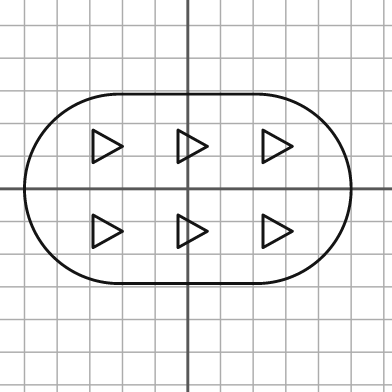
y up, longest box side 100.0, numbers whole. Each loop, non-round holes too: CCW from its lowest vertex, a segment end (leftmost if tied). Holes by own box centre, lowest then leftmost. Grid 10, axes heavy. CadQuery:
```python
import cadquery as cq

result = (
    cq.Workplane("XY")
    .moveTo(-21.0, -29.0)
    .lineTo(21.0, -29.0)
    .threePointArc((50.0, 0.0), (21.0, 29.0))
    .lineTo(-21.0, 29.0)
    .threePointArc((-50.0, 0.0), (-21.0, -29.0))
    .close()
    .moveTo(-29.0, -18.0)
    .lineTo(-20.0, -13.0)
    .lineTo(-29.0, -8.0)
    .close()
    .moveTo(-3.0, -18.0)
    .lineTo(6.0, -13.0)
    .lineTo(-3.0, -8.0)
    .close()
    .moveTo(23.0, -18.0)
    .lineTo(32.0, -13.0)
    .lineTo(23.0, -8.0)
    .close()
    .moveTo(-29.0, 8.0)
    .lineTo(-20.0, 13.0)
    .lineTo(-29.0, 18.0)
    .close()
    .moveTo(-3.0, 8.0)
    .lineTo(6.0, 13.0)
    .lineTo(-3.0, 18.0)
    .close()
    .moveTo(23.0, 8.0)
    .lineTo(32.0, 13.0)
    .lineTo(23.0, 18.0)
    .close()
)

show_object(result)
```